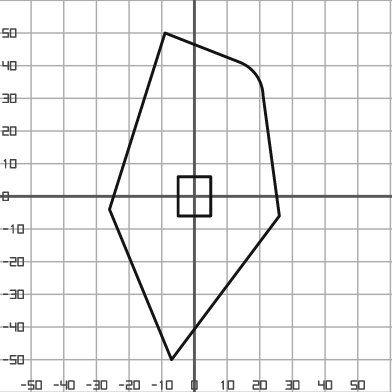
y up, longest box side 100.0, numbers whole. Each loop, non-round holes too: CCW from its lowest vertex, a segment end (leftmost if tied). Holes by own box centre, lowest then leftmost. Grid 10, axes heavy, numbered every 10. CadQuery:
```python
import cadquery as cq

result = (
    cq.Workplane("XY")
    .moveTo(-7.0, -50.0)
    .lineTo(26.0, -6.0)
    .lineTo(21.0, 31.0)
    .threePointArc((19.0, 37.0), (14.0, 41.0))
    .lineTo(-9.0, 50.0)
    .lineTo(-26.0, -4.0)
    .close()
    .moveTo(-5.0, -6.0)
    .lineTo(5.0, -6.0)
    .lineTo(5.0, 6.0)
    .lineTo(-5.0, 6.0)
    .close()
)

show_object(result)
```